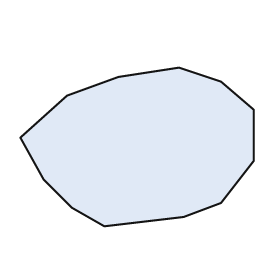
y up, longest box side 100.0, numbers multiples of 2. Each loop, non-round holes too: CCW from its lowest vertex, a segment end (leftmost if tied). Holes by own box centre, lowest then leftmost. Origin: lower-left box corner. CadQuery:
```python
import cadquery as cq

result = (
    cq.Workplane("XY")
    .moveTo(36.0, 0.0)
    .lineTo(70.0, 4.0)
    .lineTo(86.0, 10.0)
    .lineTo(100.0, 28.0)
    .lineTo(100.0, 50.0)
    .lineTo(86.0, 62.0)
    .lineTo(68.0, 68.0)
    .lineTo(42.0, 64.0)
    .lineTo(20.0, 56.0)
    .lineTo(0.0, 38.0)
    .lineTo(10.0, 20.0)
    .lineTo(22.0, 8.0)
    .close()
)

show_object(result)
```